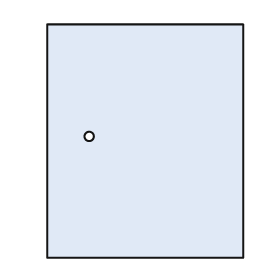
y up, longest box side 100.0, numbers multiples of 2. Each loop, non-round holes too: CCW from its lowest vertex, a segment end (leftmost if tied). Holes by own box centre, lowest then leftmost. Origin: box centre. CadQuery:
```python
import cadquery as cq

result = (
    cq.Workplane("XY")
    .moveTo(-42.0, -50.0)
    .lineTo(42.0, -50.0)
    .lineTo(42.0, 50.0)
    .lineTo(-42.0, 50.0)
    .close()
    .moveTo(-24.0, 2.0)
    .circle(2.0)
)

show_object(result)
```